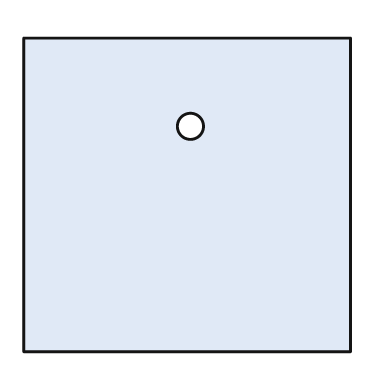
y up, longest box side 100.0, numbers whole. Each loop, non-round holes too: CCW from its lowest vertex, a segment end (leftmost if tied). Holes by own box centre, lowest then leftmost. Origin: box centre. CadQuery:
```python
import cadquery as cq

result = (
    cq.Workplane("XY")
    .moveTo(-50.0, -48.0)
    .lineTo(50.0, -48.0)
    .lineTo(50.0, 48.0)
    .lineTo(-50.0, 48.0)
    .close()
    .moveTo(1.0, 21.0)
    .circle(4.0)
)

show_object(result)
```